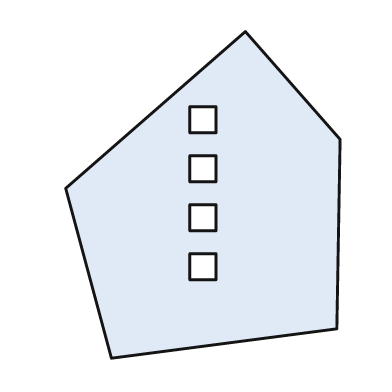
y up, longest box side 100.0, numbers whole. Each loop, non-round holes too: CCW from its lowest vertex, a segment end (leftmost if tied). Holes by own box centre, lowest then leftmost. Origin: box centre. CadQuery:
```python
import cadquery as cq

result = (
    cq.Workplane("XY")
    .moveTo(-28.0, -50.0)
    .lineTo(41.0, -41.0)
    .lineTo(42.0, 17.0)
    .lineTo(13.0, 50.0)
    .lineTo(-42.0, 2.0)
    .close()
    .moveTo(-4.0, -26.0)
    .lineTo(4.0, -26.0)
    .lineTo(4.0, -18.0)
    .lineTo(-4.0, -18.0)
    .close()
    .moveTo(-4.0, -11.0)
    .lineTo(4.0, -11.0)
    .lineTo(4.0, -3.0)
    .lineTo(-4.0, -3.0)
    .close()
    .moveTo(-4.0, 4.0)
    .lineTo(4.0, 4.0)
    .lineTo(4.0, 12.0)
    .lineTo(-4.0, 12.0)
    .close()
    .moveTo(-4.0, 19.0)
    .lineTo(4.0, 19.0)
    .lineTo(4.0, 27.0)
    .lineTo(-4.0, 27.0)
    .close()
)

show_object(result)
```